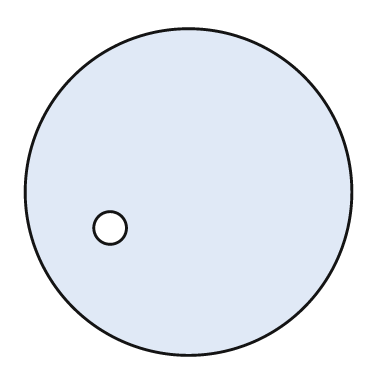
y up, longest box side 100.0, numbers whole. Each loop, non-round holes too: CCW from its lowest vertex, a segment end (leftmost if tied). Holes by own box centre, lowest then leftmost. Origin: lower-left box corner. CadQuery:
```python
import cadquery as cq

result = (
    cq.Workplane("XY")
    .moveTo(50.0, 50.0)
    .circle(50.0)
    .moveTo(26.0, 39.0)
    .circle(5.0)
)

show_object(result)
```